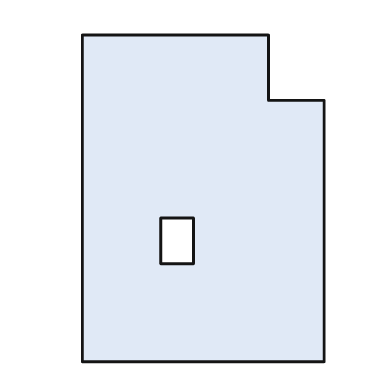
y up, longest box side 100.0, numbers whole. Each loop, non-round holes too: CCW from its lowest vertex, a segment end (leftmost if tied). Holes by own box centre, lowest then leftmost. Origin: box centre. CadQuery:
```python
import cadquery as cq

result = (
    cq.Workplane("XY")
    .moveTo(-37.0, -50.0)
    .lineTo(37.0, -50.0)
    .lineTo(37.0, 30.0)
    .lineTo(20.0, 30.0)
    .lineTo(20.0, 50.0)
    .lineTo(-37.0, 50.0)
    .close()
    .moveTo(-13.0, -20.0)
    .lineTo(-3.0, -20.0)
    .lineTo(-3.0, -6.0)
    .lineTo(-13.0, -6.0)
    .close()
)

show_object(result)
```